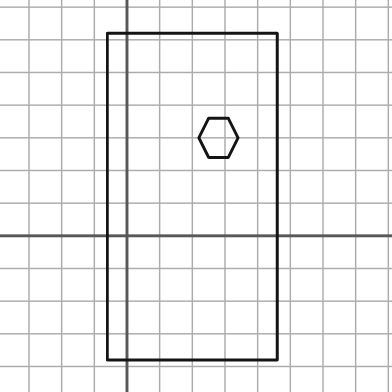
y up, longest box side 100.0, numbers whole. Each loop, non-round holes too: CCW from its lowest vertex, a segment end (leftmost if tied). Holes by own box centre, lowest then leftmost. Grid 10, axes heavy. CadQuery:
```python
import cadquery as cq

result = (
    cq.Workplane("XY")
    .moveTo(-6.0, -38.0)
    .lineTo(46.0, -38.0)
    .lineTo(46.0, 62.0)
    .lineTo(-6.0, 62.0)
    .close()
    .moveTo(25.0, 24.0)
    .lineTo(31.0, 24.0)
    .lineTo(34.0, 30.0)
    .lineTo(31.0, 36.0)
    .lineTo(25.0, 36.0)
    .lineTo(22.0, 30.0)
    .close()
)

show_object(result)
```